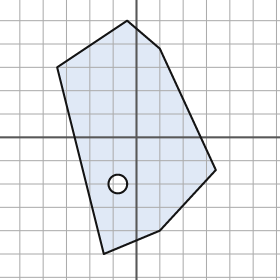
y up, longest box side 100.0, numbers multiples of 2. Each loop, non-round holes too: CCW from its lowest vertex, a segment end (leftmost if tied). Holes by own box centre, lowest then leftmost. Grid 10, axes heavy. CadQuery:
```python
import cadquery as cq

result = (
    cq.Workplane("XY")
    .moveTo(-14.0, -50.0)
    .lineTo(10.0, -40.0)
    .lineTo(34.0, -14.0)
    .lineTo(10.0, 38.0)
    .lineTo(-4.0, 50.0)
    .lineTo(-34.0, 30.0)
    .close()
    .moveTo(-8.0, -20.0)
    .circle(4.0)
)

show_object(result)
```